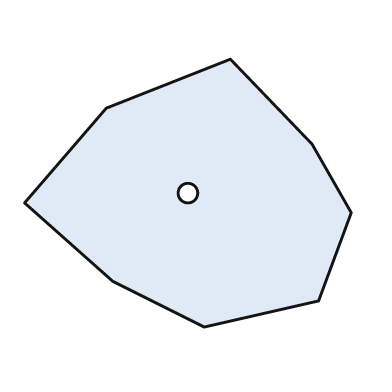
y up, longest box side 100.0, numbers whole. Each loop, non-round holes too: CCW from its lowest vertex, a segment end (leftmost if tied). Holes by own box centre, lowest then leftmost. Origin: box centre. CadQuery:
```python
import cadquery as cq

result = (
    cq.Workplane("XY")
    .moveTo(5.0, -41.0)
    .lineTo(40.0, -33.0)
    .lineTo(50.0, -6.0)
    .lineTo(38.0, 15.0)
    .lineTo(13.0, 41.0)
    .lineTo(-25.0, 26.0)
    .lineTo(-50.0, -3.0)
    .lineTo(-23.0, -27.0)
    .close()
    .moveTo(0.0, 0.0)
    .circle(3.0)
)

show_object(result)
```